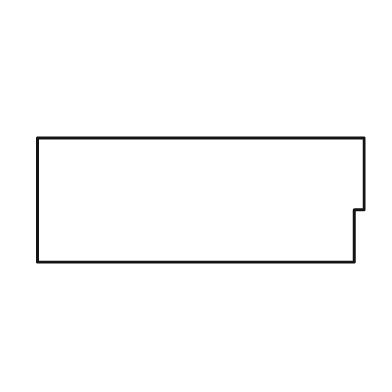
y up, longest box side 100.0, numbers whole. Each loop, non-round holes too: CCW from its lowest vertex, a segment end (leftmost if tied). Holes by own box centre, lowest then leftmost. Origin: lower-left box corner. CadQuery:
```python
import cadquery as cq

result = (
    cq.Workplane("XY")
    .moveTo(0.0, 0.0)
    .lineTo(97.0, 0.0)
    .lineTo(97.0, 16.0)
    .lineTo(100.0, 16.0)
    .lineTo(100.0, 38.0)
    .lineTo(0.0, 38.0)
    .close()
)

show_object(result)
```